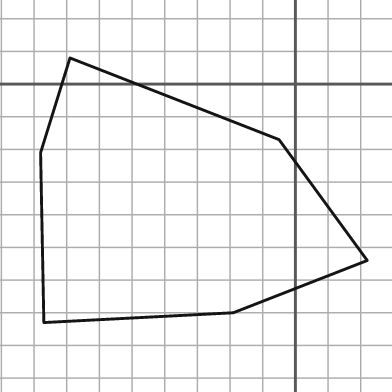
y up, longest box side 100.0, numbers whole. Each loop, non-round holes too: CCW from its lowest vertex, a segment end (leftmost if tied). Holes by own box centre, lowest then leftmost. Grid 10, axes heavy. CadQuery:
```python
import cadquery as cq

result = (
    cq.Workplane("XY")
    .moveTo(-77.0, -73.0)
    .lineTo(-19.0, -70.0)
    .lineTo(22.0, -54.0)
    .lineTo(-5.0, -17.0)
    .lineTo(-69.0, 8.0)
    .lineTo(-78.0, -21.0)
    .close()
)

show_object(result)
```